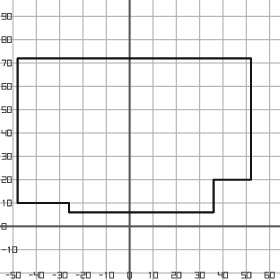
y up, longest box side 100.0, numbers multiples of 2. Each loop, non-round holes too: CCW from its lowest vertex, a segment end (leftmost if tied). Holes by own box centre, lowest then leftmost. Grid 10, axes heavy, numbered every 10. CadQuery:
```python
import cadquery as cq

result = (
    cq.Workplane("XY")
    .moveTo(-26.0, 6.0)
    .lineTo(36.0, 6.0)
    .lineTo(36.0, 20.0)
    .lineTo(52.0, 20.0)
    .lineTo(52.0, 72.0)
    .lineTo(-48.0, 72.0)
    .lineTo(-48.0, 10.0)
    .lineTo(-26.0, 10.0)
    .close()
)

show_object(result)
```